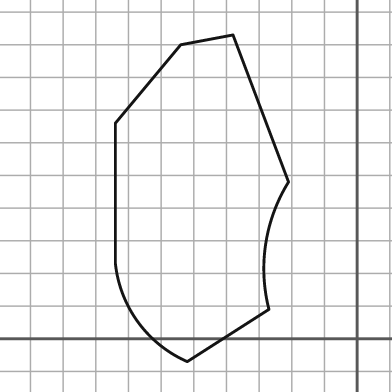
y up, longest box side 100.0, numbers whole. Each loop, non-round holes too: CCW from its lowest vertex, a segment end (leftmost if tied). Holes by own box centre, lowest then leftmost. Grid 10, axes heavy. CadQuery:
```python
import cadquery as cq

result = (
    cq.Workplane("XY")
    .moveTo(-52.0, -7.0)
    .lineTo(-27.0, 9.0)
    .threePointArc((-28.0, 29.0), (-21.0, 48.0))
    .lineTo(-38.0, 93.0)
    .lineTo(-54.0, 90.0)
    .lineTo(-74.0, 66.0)
    .lineTo(-74.0, 23.0)
    .threePointArc((-67.0, 5.0), (-52.0, -7.0))
    .close()
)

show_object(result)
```